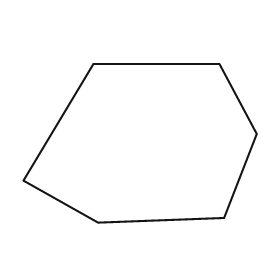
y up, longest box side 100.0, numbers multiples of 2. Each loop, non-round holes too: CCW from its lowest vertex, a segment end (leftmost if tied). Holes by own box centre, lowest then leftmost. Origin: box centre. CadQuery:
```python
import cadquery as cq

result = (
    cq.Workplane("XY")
    .moveTo(-18.0, -34.0)
    .lineTo(36.0, -32.0)
    .lineTo(50.0, 4.0)
    .lineTo(34.0, 34.0)
    .lineTo(-20.0, 34.0)
    .lineTo(-50.0, -16.0)
    .close()
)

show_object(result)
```